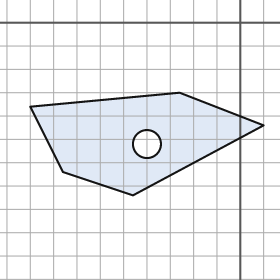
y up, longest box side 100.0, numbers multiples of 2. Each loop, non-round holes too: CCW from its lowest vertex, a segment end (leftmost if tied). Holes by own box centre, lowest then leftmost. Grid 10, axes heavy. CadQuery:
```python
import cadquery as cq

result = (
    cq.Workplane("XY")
    .moveTo(-46.0, -74.0)
    .lineTo(10.0, -44.0)
    .lineTo(-26.0, -30.0)
    .lineTo(-90.0, -36.0)
    .lineTo(-76.0, -64.0)
    .close()
    .moveTo(-40.0, -52.0)
    .circle(6.0)
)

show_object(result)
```